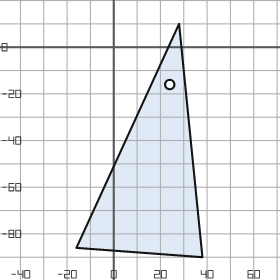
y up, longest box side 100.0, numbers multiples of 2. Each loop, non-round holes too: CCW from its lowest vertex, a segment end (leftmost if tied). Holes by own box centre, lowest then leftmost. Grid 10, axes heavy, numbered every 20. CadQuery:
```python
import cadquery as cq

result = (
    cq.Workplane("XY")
    .moveTo(38.0, -90.0)
    .lineTo(28.0, 10.0)
    .lineTo(-16.0, -86.0)
    .close()
    .moveTo(24.0, -16.0)
    .circle(2.0)
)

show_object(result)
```